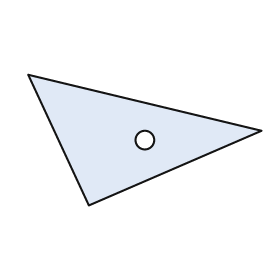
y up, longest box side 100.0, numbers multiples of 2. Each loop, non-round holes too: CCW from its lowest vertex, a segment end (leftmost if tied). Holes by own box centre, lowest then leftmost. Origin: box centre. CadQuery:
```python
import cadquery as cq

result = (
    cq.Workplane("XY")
    .moveTo(-24.0, -28.0)
    .lineTo(50.0, 4.0)
    .lineTo(-50.0, 28.0)
    .close()
    .moveTo(0.0, 0.0)
    .circle(4.0)
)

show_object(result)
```